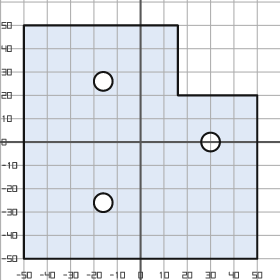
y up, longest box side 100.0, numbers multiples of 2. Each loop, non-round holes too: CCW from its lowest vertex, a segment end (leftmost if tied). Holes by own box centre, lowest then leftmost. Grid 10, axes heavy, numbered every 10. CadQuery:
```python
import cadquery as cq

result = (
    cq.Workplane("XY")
    .moveTo(-50.0, -50.0)
    .lineTo(50.0, -50.0)
    .lineTo(50.0, 20.0)
    .lineTo(16.0, 20.0)
    .lineTo(16.0, 50.0)
    .lineTo(-50.0, 50.0)
    .close()
    .moveTo(-16.0, -26.0)
    .circle(4.0)
    .moveTo(30.0, 0.0)
    .circle(4.0)
    .moveTo(-16.0, 26.0)
    .circle(4.0)
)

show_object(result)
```